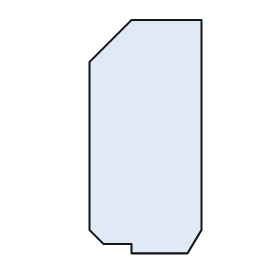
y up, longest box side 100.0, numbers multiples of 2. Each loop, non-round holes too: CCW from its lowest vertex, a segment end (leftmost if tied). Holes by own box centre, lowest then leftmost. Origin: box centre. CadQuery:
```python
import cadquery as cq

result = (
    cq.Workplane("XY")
    .moveTo(-6.0, -50.0)
    .lineTo(18.0, -50.0)
    .lineTo(24.0, -40.0)
    .lineTo(24.0, 50.0)
    .lineTo(-6.0, 50.0)
    .lineTo(-24.0, 32.0)
    .lineTo(-24.0, -40.0)
    .lineTo(-18.0, -46.0)
    .lineTo(-6.0, -46.0)
    .close()
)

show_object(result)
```